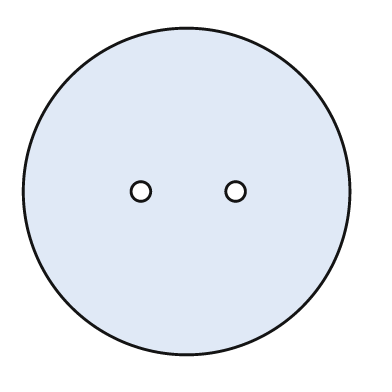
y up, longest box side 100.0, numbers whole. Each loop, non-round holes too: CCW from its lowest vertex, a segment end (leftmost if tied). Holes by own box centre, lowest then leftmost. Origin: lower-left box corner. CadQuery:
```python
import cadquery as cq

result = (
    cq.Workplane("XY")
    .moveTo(50.0, 50.0)
    .circle(50.0)
    .moveTo(36.0, 50.0)
    .circle(3.0)
    .moveTo(65.0, 50.0)
    .circle(3.0)
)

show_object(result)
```